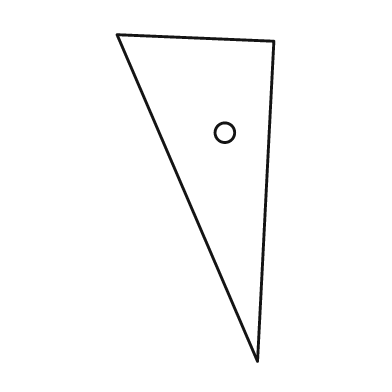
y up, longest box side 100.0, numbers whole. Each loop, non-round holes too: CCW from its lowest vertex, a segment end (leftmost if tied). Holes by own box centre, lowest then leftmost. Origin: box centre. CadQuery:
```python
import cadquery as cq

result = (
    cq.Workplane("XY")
    .moveTo(19.0, -50.0)
    .lineTo(24.0, 48.0)
    .lineTo(-24.0, 50.0)
    .close()
    .moveTo(9.0, 20.0)
    .circle(3.0)
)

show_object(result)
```